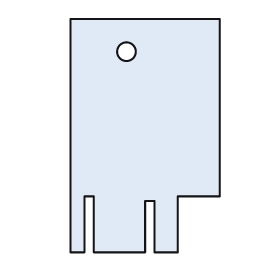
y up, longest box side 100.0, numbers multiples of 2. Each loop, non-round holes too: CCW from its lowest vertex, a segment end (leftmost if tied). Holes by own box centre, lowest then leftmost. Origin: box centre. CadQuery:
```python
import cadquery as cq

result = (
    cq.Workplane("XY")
    .moveTo(-32.0, -50.0)
    .lineTo(-26.0, -50.0)
    .lineTo(-26.0, -26.0)
    .lineTo(-22.0, -26.0)
    .lineTo(-22.0, -50.0)
    .lineTo(0.0, -50.0)
    .lineTo(0.0, -28.0)
    .lineTo(4.0, -28.0)
    .lineTo(4.0, -50.0)
    .lineTo(14.0, -50.0)
    .lineTo(14.0, -26.0)
    .lineTo(32.0, -26.0)
    .lineTo(32.0, 50.0)
    .lineTo(-32.0, 50.0)
    .close()
    .moveTo(-8.0, 36.0)
    .circle(4.0)
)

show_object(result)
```